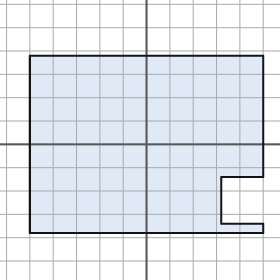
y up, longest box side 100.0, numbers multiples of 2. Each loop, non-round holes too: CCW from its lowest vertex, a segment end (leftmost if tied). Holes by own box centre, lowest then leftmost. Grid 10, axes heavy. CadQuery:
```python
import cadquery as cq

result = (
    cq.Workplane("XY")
    .moveTo(-50.0, -38.0)
    .lineTo(50.0, -38.0)
    .lineTo(50.0, -34.0)
    .lineTo(32.0, -34.0)
    .lineTo(32.0, -14.0)
    .lineTo(50.0, -14.0)
    .lineTo(50.0, 38.0)
    .lineTo(-50.0, 38.0)
    .close()
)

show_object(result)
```